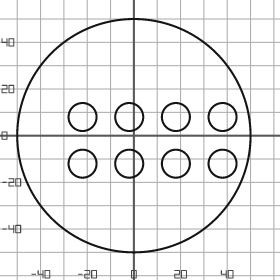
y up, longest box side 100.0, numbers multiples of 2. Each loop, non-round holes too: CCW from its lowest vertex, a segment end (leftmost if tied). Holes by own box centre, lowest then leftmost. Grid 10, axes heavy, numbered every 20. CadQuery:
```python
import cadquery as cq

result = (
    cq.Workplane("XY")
    .moveTo(0.0, 0.0)
    .circle(50.0)
    .moveTo(-22.0, -12.0)
    .circle(6.0)
    .moveTo(-2.0, -12.0)
    .circle(6.0)
    .moveTo(18.0, -12.0)
    .circle(6.0)
    .moveTo(38.0, -12.0)
    .circle(6.0)
    .moveTo(-22.0, 8.0)
    .circle(6.0)
    .moveTo(-2.0, 8.0)
    .circle(6.0)
    .moveTo(18.0, 8.0)
    .circle(6.0)
    .moveTo(38.0, 8.0)
    .circle(6.0)
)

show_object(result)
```